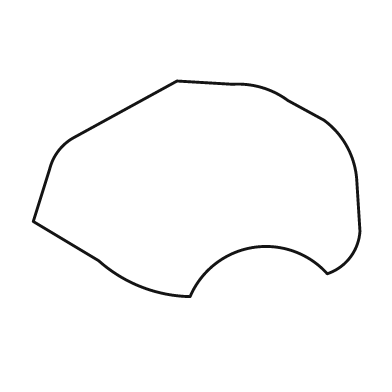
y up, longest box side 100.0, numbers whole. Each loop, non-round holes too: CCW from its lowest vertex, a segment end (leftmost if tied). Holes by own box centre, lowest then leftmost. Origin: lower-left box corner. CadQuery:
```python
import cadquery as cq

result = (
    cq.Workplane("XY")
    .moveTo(48.0, 0.0)
    .threePointArc((67.0, 15.0), (90.0, 7.0))
    .threePointArc((97.0, 12.0), (100.0, 20.0))
    .lineTo(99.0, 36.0)
    .threePointArc((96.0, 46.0), (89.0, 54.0))
    .lineTo(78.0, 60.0)
    .threePointArc((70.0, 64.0), (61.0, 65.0))
    .lineTo(44.0, 66.0)
    .lineTo(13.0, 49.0)
    .threePointArc((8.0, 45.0), (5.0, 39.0))
    .lineTo(0.0, 23.0)
    .lineTo(20.0, 11.0)
    .threePointArc((33.0, 3.0), (48.0, 0.0))
    .close()
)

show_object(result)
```